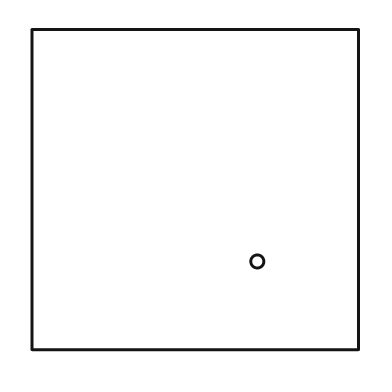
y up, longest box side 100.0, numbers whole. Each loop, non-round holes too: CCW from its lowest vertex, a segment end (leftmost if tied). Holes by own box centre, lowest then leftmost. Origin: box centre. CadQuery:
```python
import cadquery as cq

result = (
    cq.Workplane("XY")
    .moveTo(-50.0, -49.0)
    .lineTo(50.0, -49.0)
    .lineTo(50.0, 49.0)
    .lineTo(-50.0, 49.0)
    .close()
    .moveTo(19.0, -22.0)
    .circle(2.0)
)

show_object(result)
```